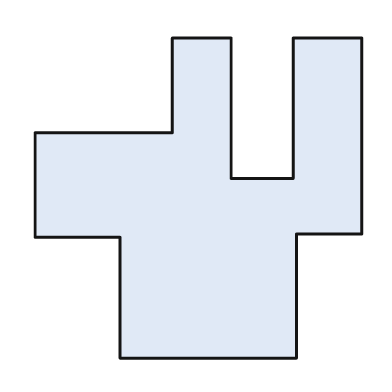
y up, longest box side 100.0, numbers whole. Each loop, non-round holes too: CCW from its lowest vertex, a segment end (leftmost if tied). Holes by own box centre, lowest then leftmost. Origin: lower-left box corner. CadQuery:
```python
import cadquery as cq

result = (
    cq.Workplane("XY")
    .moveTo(26.0, 0.0)
    .lineTo(80.0, 0.0)
    .lineTo(80.0, 38.0)
    .lineTo(100.0, 38.0)
    .lineTo(100.0, 98.0)
    .lineTo(79.0, 98.0)
    .lineTo(79.0, 55.0)
    .lineTo(60.0, 55.0)
    .lineTo(60.0, 98.0)
    .lineTo(42.0, 98.0)
    .lineTo(42.0, 69.0)
    .lineTo(0.0, 69.0)
    .lineTo(0.0, 37.0)
    .lineTo(26.0, 37.0)
    .close()
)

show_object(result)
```